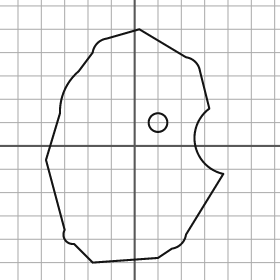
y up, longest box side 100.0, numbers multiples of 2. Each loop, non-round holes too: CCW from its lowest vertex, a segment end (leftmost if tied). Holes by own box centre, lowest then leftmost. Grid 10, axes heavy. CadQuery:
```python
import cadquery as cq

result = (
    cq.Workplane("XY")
    .moveTo(-18.0, -50.0)
    .lineTo(10.0, -48.0)
    .lineTo(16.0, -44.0)
    .threePointArc((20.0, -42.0), (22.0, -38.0))
    .lineTo(38.0, -12.0)
    .threePointArc((26.0, 0.0), (32.0, 16.0))
    .lineTo(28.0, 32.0)
    .threePointArc((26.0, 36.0), (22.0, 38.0))
    .lineTo(2.0, 50.0)
    .lineTo(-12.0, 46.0)
    .threePointArc((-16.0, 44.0), (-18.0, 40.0))
    .lineTo(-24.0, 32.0)
    .threePointArc((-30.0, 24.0), (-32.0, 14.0))
    .lineTo(-38.0, -6.0)
    .lineTo(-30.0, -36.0)
    .threePointArc((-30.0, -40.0), (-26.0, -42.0))
    .close()
    .moveTo(10.0, 10.0)
    .circle(4.0)
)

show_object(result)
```